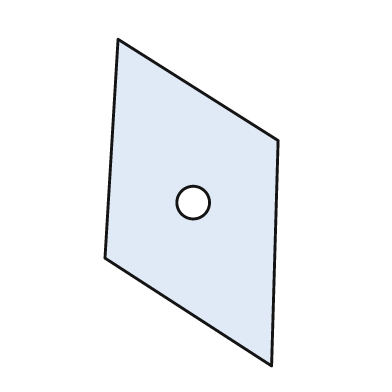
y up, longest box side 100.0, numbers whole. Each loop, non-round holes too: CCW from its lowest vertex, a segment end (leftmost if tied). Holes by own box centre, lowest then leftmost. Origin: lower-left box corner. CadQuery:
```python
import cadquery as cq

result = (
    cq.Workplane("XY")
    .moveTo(51.0, 0.0)
    .lineTo(53.0, 69.0)
    .lineTo(4.0, 100.0)
    .lineTo(0.0, 33.0)
    .close()
    .moveTo(27.0, 50.0)
    .circle(5.0)
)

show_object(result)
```